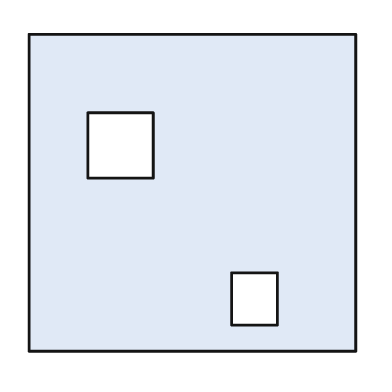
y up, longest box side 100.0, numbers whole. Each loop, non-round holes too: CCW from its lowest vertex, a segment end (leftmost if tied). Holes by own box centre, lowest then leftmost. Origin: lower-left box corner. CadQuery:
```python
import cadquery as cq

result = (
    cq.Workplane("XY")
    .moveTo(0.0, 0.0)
    .lineTo(100.0, 0.0)
    .lineTo(100.0, 97.0)
    .lineTo(0.0, 97.0)
    .close()
    .moveTo(62.0, 8.0)
    .lineTo(76.0, 8.0)
    .lineTo(76.0, 24.0)
    .lineTo(62.0, 24.0)
    .close()
    .moveTo(18.0, 53.0)
    .lineTo(38.0, 53.0)
    .lineTo(38.0, 73.0)
    .lineTo(18.0, 73.0)
    .close()
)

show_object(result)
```